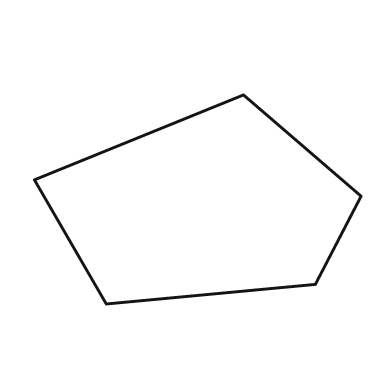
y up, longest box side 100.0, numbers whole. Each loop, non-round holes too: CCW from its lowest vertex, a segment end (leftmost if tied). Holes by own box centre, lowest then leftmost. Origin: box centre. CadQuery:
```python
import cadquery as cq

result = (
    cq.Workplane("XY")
    .moveTo(-28.0, -32.0)
    .lineTo(36.0, -26.0)
    .lineTo(50.0, 1.0)
    .lineTo(14.0, 32.0)
    .lineTo(-50.0, 6.0)
    .close()
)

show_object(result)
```